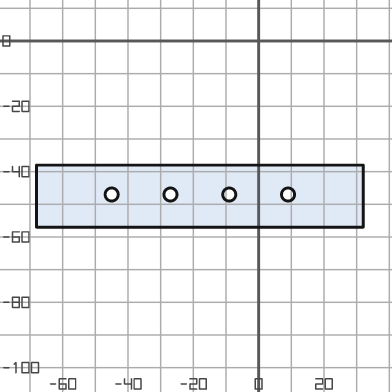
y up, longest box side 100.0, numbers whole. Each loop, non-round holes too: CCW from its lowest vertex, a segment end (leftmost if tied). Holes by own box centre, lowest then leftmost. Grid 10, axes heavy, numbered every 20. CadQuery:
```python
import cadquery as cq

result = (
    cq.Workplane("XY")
    .moveTo(-68.0, -57.0)
    .lineTo(32.0, -57.0)
    .lineTo(32.0, -38.0)
    .lineTo(-68.0, -38.0)
    .close()
    .moveTo(-45.0, -47.0)
    .circle(2.0)
    .moveTo(-27.0, -47.0)
    .circle(2.0)
    .moveTo(-9.0, -47.0)
    .circle(2.0)
    .moveTo(9.0, -47.0)
    .circle(2.0)
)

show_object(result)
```